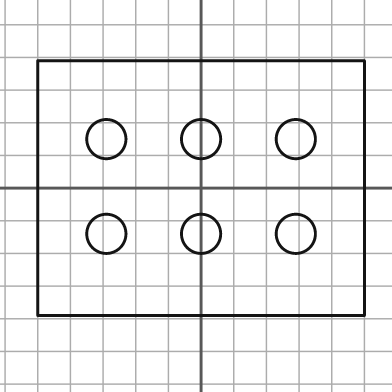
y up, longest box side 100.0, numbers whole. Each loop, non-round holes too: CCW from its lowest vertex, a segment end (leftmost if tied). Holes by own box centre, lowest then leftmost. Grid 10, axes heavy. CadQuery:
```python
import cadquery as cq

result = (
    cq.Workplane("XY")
    .moveTo(-50.0, -39.0)
    .lineTo(50.0, -39.0)
    .lineTo(50.0, 39.0)
    .lineTo(-50.0, 39.0)
    .close()
    .moveTo(-29.0, -14.0)
    .circle(6.0)
    .moveTo(0.0, -14.0)
    .circle(6.0)
    .moveTo(29.0, -14.0)
    .circle(6.0)
    .moveTo(-29.0, 15.0)
    .circle(6.0)
    .moveTo(0.0, 15.0)
    .circle(6.0)
    .moveTo(29.0, 15.0)
    .circle(6.0)
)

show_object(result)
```